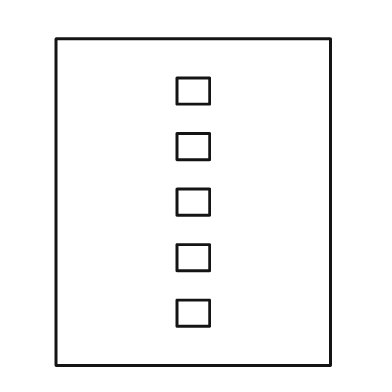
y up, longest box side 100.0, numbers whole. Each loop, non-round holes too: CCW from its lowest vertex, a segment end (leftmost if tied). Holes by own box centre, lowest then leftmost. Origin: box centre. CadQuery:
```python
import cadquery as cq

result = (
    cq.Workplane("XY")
    .moveTo(-42.0, -50.0)
    .lineTo(42.0, -50.0)
    .lineTo(42.0, 50.0)
    .lineTo(-42.0, 50.0)
    .close()
    .moveTo(-5.0, -38.0)
    .lineTo(5.0, -38.0)
    .lineTo(5.0, -30.0)
    .lineTo(-5.0, -30.0)
    .close()
    .moveTo(-5.0, -21.0)
    .lineTo(5.0, -21.0)
    .lineTo(5.0, -13.0)
    .lineTo(-5.0, -13.0)
    .close()
    .moveTo(-5.0, -4.0)
    .lineTo(5.0, -4.0)
    .lineTo(5.0, 4.0)
    .lineTo(-5.0, 4.0)
    .close()
    .moveTo(-5.0, 13.0)
    .lineTo(5.0, 13.0)
    .lineTo(5.0, 21.0)
    .lineTo(-5.0, 21.0)
    .close()
    .moveTo(-5.0, 30.0)
    .lineTo(5.0, 30.0)
    .lineTo(5.0, 38.0)
    .lineTo(-5.0, 38.0)
    .close()
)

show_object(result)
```